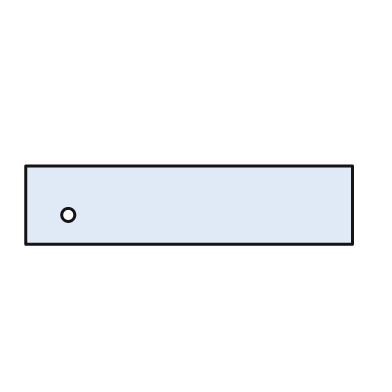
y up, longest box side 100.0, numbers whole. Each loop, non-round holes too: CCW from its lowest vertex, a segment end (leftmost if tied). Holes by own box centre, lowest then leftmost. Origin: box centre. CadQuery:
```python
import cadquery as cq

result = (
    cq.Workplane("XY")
    .moveTo(-50.0, -12.0)
    .lineTo(50.0, -12.0)
    .lineTo(50.0, 12.0)
    .lineTo(-50.0, 12.0)
    .close()
    .moveTo(-37.0, -3.0)
    .circle(2.0)
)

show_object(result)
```